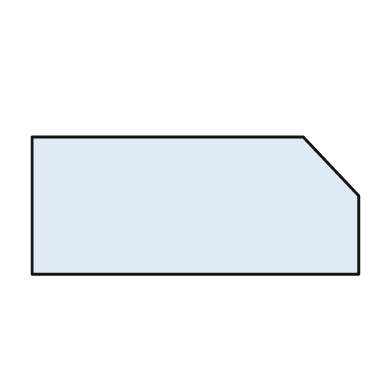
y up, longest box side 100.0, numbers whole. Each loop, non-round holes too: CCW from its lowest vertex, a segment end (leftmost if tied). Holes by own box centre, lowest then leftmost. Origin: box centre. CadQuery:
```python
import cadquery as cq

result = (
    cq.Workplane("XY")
    .moveTo(-50.0, -21.0)
    .lineTo(50.0, -21.0)
    .lineTo(50.0, 3.0)
    .lineTo(33.0, 21.0)
    .lineTo(-50.0, 21.0)
    .close()
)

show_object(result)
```